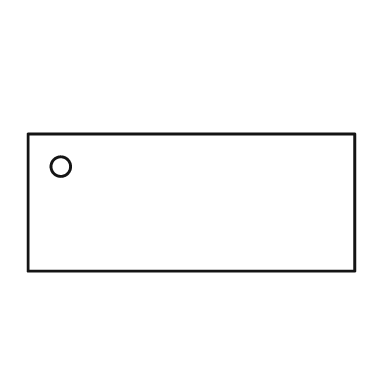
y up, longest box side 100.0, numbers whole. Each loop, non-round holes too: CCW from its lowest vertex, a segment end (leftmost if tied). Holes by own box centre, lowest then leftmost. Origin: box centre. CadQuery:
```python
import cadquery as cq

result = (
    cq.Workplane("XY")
    .moveTo(-50.0, -21.0)
    .lineTo(50.0, -21.0)
    .lineTo(50.0, 21.0)
    .lineTo(-50.0, 21.0)
    .close()
    .moveTo(-40.0, 11.0)
    .circle(3.0)
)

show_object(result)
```